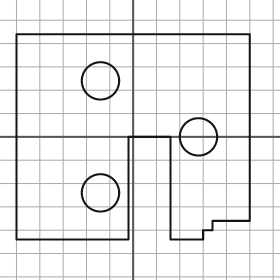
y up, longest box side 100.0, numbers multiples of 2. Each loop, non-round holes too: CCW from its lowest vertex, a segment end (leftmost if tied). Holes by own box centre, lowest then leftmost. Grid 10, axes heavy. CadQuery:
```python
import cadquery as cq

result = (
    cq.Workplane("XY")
    .moveTo(-50.0, -44.0)
    .lineTo(-2.0, -44.0)
    .lineTo(-2.0, 0.0)
    .lineTo(16.0, 0.0)
    .lineTo(16.0, -44.0)
    .lineTo(30.0, -44.0)
    .lineTo(30.0, -40.0)
    .lineTo(34.0, -40.0)
    .lineTo(34.0, -36.0)
    .lineTo(50.0, -36.0)
    .lineTo(50.0, 44.0)
    .lineTo(-50.0, 44.0)
    .close()
    .moveTo(-14.0, -24.0)
    .circle(8.0)
    .moveTo(28.0, 0.0)
    .circle(8.0)
    .moveTo(-14.0, 24.0)
    .circle(8.0)
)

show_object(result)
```